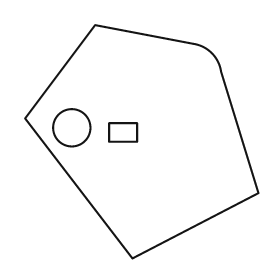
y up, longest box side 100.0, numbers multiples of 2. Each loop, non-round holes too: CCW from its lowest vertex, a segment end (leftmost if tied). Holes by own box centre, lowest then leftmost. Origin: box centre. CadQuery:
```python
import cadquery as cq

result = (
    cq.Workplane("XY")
    .moveTo(-4.0, -50.0)
    .lineTo(50.0, -22.0)
    .lineTo(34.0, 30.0)
    .threePointArc((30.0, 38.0), (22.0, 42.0))
    .lineTo(-20.0, 50.0)
    .lineTo(-50.0, 10.0)
    .close()
    .moveTo(-14.0, 0.0)
    .lineTo(-2.0, 0.0)
    .lineTo(-2.0, 8.0)
    .lineTo(-14.0, 8.0)
    .close()
    .moveTo(-30.0, 6.0)
    .circle(8.0)
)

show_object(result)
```